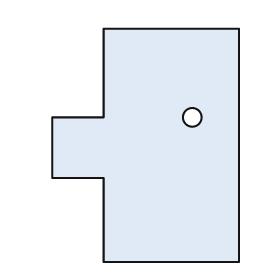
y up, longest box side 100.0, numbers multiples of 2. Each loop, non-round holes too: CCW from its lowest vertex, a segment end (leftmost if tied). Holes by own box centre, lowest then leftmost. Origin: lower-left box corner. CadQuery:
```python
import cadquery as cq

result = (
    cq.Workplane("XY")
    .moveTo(22.0, 0.0)
    .lineTo(80.0, 0.0)
    .lineTo(80.0, 100.0)
    .lineTo(22.0, 100.0)
    .lineTo(22.0, 62.0)
    .lineTo(0.0, 62.0)
    .lineTo(0.0, 36.0)
    .lineTo(22.0, 36.0)
    .close()
    .moveTo(60.0, 62.0)
    .circle(4.0)
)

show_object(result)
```